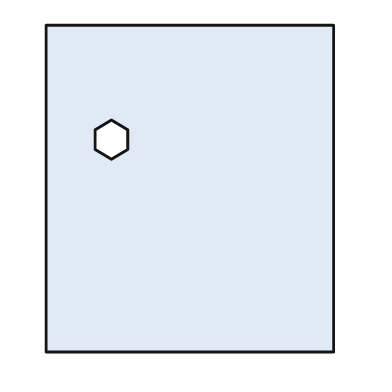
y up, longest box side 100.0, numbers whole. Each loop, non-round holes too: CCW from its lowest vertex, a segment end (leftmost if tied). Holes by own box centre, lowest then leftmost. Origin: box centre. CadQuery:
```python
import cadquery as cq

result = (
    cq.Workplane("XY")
    .moveTo(-44.0, -50.0)
    .lineTo(44.0, -50.0)
    .lineTo(44.0, 50.0)
    .lineTo(-44.0, 50.0)
    .close()
    .moveTo(-24.0, 9.0)
    .lineTo(-19.0, 12.0)
    .lineTo(-19.0, 18.0)
    .lineTo(-24.0, 21.0)
    .lineTo(-29.0, 18.0)
    .lineTo(-29.0, 12.0)
    .close()
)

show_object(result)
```